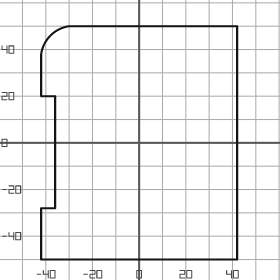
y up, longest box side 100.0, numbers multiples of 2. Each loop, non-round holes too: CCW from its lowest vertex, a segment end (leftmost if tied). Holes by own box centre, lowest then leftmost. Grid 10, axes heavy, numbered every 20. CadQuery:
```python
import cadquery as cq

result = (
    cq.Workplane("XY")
    .moveTo(-42.0, -50.0)
    .lineTo(42.0, -50.0)
    .lineTo(42.0, 50.0)
    .lineTo(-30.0, 50.0)
    .threePointArc((-38.0, 46.0), (-42.0, 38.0))
    .lineTo(-42.0, 20.0)
    .lineTo(-36.0, 20.0)
    .lineTo(-36.0, -28.0)
    .lineTo(-42.0, -28.0)
    .close()
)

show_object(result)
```